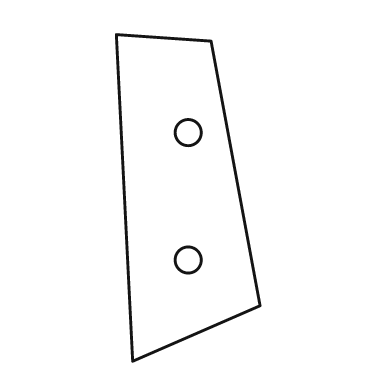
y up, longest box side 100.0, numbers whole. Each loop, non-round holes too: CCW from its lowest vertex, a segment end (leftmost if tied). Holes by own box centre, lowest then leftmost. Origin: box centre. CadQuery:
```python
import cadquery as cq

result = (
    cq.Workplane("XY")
    .moveTo(-17.0, -50.0)
    .lineTo(22.0, -33.0)
    .lineTo(7.0, 48.0)
    .lineTo(-22.0, 50.0)
    .close()
    .moveTo(0.0, -19.0)
    .circle(4.0)
    .moveTo(0.0, 20.0)
    .circle(4.0)
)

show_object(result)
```